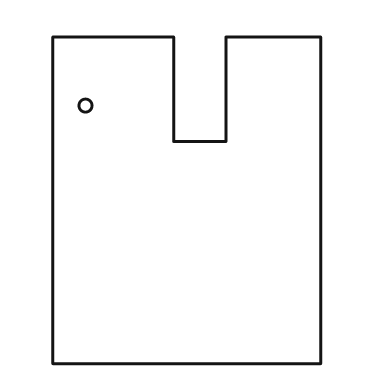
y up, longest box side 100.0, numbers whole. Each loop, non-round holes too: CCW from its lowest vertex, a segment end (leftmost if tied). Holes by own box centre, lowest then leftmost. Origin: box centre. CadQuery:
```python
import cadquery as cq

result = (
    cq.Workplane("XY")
    .moveTo(-41.0, -50.0)
    .lineTo(41.0, -50.0)
    .lineTo(41.0, 50.0)
    .lineTo(12.0, 50.0)
    .lineTo(12.0, 18.0)
    .lineTo(-4.0, 18.0)
    .lineTo(-4.0, 50.0)
    .lineTo(-41.0, 50.0)
    .close()
    .moveTo(-31.0, 29.0)
    .circle(2.0)
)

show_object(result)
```